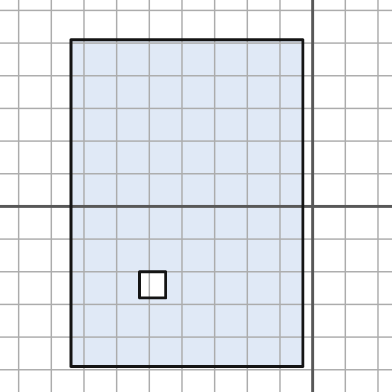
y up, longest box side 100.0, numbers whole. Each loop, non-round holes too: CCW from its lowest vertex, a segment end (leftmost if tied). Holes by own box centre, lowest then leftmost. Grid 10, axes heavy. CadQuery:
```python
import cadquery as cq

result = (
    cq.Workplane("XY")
    .moveTo(-74.0, -49.0)
    .lineTo(-3.0, -49.0)
    .lineTo(-3.0, 51.0)
    .lineTo(-74.0, 51.0)
    .close()
    .moveTo(-53.0, -28.0)
    .lineTo(-45.0, -28.0)
    .lineTo(-45.0, -20.0)
    .lineTo(-53.0, -20.0)
    .close()
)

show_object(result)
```